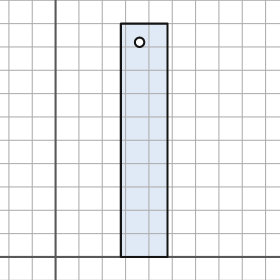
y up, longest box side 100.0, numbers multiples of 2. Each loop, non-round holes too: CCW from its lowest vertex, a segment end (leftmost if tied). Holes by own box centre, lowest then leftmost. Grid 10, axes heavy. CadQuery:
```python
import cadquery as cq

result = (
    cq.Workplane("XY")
    .moveTo(28.0, 0.0)
    .lineTo(48.0, 0.0)
    .lineTo(48.0, 100.0)
    .lineTo(28.0, 100.0)
    .close()
    .moveTo(36.0, 92.0)
    .circle(2.0)
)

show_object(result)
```